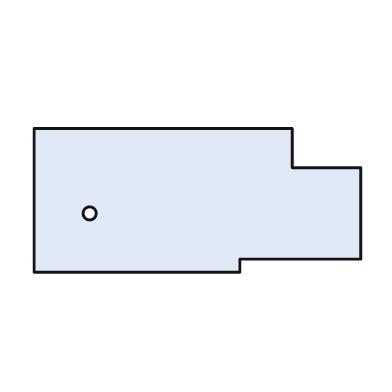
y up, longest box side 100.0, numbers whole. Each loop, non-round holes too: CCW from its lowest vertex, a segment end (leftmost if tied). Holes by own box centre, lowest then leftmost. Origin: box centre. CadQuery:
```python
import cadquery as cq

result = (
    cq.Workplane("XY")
    .moveTo(-50.0, -22.0)
    .lineTo(13.0, -22.0)
    .lineTo(13.0, -18.0)
    .lineTo(50.0, -18.0)
    .lineTo(50.0, 10.0)
    .lineTo(29.0, 10.0)
    .lineTo(29.0, 22.0)
    .lineTo(-50.0, 22.0)
    .close()
    .moveTo(-33.0, -4.0)
    .circle(2.0)
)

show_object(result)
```